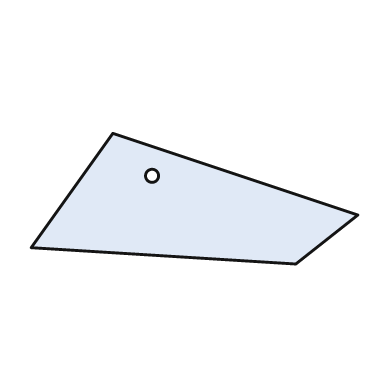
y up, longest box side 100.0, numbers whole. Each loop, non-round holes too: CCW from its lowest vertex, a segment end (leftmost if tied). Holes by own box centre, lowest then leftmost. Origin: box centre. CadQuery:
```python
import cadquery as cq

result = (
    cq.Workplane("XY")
    .moveTo(31.0, -20.0)
    .lineTo(50.0, -5.0)
    .lineTo(-25.0, 20.0)
    .lineTo(-50.0, -15.0)
    .close()
    .moveTo(-13.0, 7.0)
    .circle(2.0)
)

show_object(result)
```